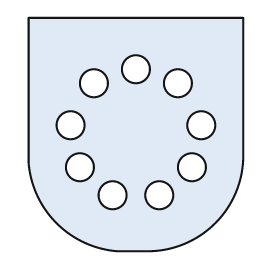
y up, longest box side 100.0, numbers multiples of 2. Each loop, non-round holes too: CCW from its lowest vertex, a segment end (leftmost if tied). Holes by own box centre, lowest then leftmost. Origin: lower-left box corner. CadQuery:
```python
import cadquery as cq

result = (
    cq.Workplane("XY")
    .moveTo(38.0, 0.0)
    .lineTo(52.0, 0.0)
    .threePointArc((80.0, 12.0), (92.0, 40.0))
    .lineTo(92.0, 100.0)
    .lineTo(0.0, 100.0)
    .lineTo(0.0, 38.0)
    .threePointArc((12.0, 12.0), (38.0, 0.0))
    .close()
    .moveTo(36.0, 24.0)
    .circle(6.0)
    .moveTo(56.0, 24.0)
    .circle(6.0)
    .moveTo(22.0, 36.0)
    .circle(6.0)
    .moveTo(70.0, 36.0)
    .circle(6.0)
    .moveTo(18.0, 54.0)
    .circle(6.0)
    .moveTo(74.0, 54.0)
    .circle(6.0)
    .moveTo(28.0, 72.0)
    .circle(6.0)
    .moveTo(64.0, 72.0)
    .circle(6.0)
    .moveTo(46.0, 78.0)
    .circle(6.0)
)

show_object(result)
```